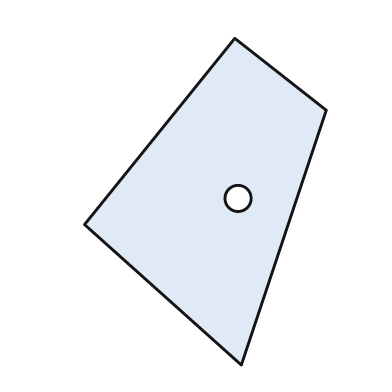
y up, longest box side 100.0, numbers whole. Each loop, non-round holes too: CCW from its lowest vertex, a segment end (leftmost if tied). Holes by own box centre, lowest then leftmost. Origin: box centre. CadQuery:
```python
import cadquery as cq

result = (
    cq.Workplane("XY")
    .moveTo(11.0, -50.0)
    .lineTo(37.0, 28.0)
    .lineTo(9.0, 50.0)
    .lineTo(-37.0, -7.0)
    .close()
    .moveTo(10.0, 1.0)
    .circle(4.0)
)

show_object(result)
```